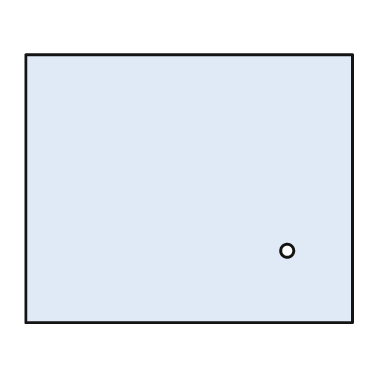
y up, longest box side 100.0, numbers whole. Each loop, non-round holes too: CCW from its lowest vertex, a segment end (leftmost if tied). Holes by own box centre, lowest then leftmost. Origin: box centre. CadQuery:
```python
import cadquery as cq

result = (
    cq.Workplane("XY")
    .moveTo(-50.0, -41.0)
    .lineTo(50.0, -41.0)
    .lineTo(50.0, 41.0)
    .lineTo(-50.0, 41.0)
    .close()
    .moveTo(30.0, -19.0)
    .circle(2.0)
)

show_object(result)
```